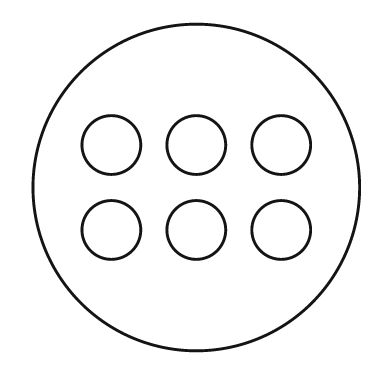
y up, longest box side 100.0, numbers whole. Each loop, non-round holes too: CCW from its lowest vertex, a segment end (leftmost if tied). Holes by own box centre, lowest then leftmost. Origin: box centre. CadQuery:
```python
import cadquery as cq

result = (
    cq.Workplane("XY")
    .moveTo(0.0, 0.0)
    .circle(50.0)
    .moveTo(-26.0, -13.0)
    .circle(9.0)
    .moveTo(0.0, -13.0)
    .circle(9.0)
    .moveTo(26.0, -13.0)
    .circle(9.0)
    .moveTo(-26.0, 13.0)
    .circle(9.0)
    .moveTo(0.0, 13.0)
    .circle(9.0)
    .moveTo(26.0, 13.0)
    .circle(9.0)
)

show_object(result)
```